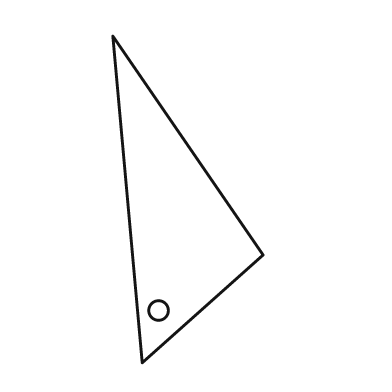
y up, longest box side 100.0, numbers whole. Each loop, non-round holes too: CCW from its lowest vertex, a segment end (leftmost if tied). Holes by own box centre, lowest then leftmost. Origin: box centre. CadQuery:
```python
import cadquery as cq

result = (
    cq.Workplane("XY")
    .moveTo(-14.0, -50.0)
    .lineTo(23.0, -17.0)
    .lineTo(-23.0, 50.0)
    .close()
    .moveTo(-9.0, -34.0)
    .circle(3.0)
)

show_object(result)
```